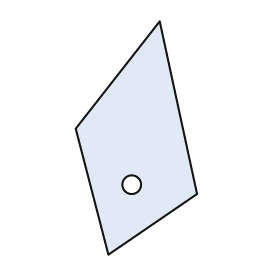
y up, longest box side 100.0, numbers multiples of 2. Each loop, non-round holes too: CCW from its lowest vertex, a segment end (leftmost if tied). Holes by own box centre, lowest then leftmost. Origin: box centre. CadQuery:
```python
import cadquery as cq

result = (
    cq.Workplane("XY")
    .moveTo(-12.0, -50.0)
    .lineTo(26.0, -24.0)
    .lineTo(10.0, 50.0)
    .lineTo(-26.0, 4.0)
    .close()
    .moveTo(-2.0, -20.0)
    .circle(4.0)
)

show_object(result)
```